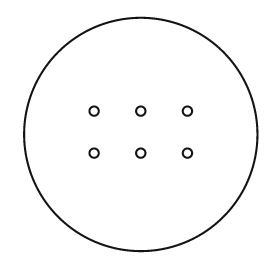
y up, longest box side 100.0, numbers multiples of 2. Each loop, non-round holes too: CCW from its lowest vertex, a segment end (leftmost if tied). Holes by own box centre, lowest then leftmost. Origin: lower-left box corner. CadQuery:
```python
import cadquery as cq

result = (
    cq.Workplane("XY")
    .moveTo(50.0, 50.0)
    .circle(50.0)
    .moveTo(30.0, 42.0)
    .circle(2.0)
    .moveTo(50.0, 42.0)
    .circle(2.0)
    .moveTo(70.0, 42.0)
    .circle(2.0)
    .moveTo(30.0, 60.0)
    .circle(2.0)
    .moveTo(50.0, 60.0)
    .circle(2.0)
    .moveTo(70.0, 60.0)
    .circle(2.0)
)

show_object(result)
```